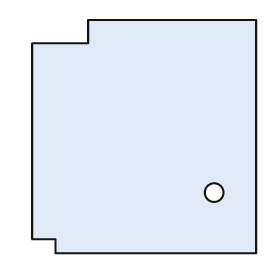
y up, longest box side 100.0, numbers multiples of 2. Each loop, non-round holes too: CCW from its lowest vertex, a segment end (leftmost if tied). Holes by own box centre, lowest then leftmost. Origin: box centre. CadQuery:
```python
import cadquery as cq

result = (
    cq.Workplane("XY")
    .moveTo(-38.0, -50.0)
    .lineTo(48.0, -50.0)
    .lineTo(48.0, 50.0)
    .lineTo(-24.0, 50.0)
    .lineTo(-24.0, 40.0)
    .lineTo(-48.0, 40.0)
    .lineTo(-48.0, -44.0)
    .lineTo(-38.0, -44.0)
    .close()
    .moveTo(30.0, -24.0)
    .circle(4.0)
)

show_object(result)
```